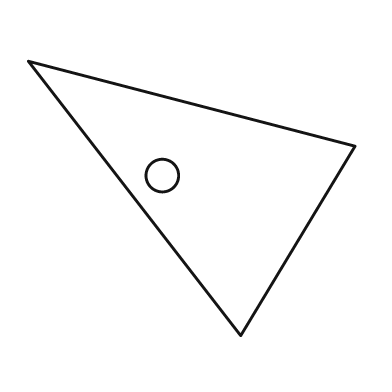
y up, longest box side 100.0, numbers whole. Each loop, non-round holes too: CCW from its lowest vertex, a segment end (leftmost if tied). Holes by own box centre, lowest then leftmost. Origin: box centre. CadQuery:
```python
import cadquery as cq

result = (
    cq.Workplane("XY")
    .moveTo(15.0, -42.0)
    .lineTo(50.0, 16.0)
    .lineTo(-50.0, 42.0)
    .close()
    .moveTo(-9.0, 7.0)
    .circle(5.0)
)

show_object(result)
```